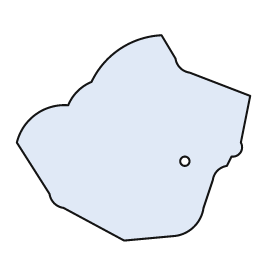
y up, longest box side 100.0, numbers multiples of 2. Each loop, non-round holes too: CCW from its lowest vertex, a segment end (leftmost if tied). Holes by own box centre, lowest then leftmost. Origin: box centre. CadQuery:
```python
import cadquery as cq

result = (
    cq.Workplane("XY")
    .moveTo(-4.0, -44.0)
    .lineTo(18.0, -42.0)
    .threePointArc((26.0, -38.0), (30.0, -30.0))
    .lineTo(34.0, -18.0)
    .threePointArc((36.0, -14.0), (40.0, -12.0))
    .lineTo(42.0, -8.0)
    .threePointArc((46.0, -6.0), (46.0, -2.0))
    .lineTo(50.0, 18.0)
    .lineTo(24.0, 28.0)
    .threePointArc((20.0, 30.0), (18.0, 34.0))
    .lineTo(12.0, 44.0)
    .threePointArc((-6.0, 38.0), (-18.0, 24.0))
    .threePointArc((-24.0, 20.0), (-28.0, 14.0))
    .threePointArc((-42.0, 10.0), (-50.0, -2.0))
    .lineTo(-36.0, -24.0)
    .threePointArc((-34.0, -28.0), (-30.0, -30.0))
    .close()
    .moveTo(22.0, -10.0)
    .circle(2.0)
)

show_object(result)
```